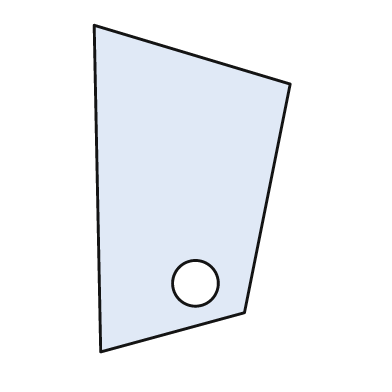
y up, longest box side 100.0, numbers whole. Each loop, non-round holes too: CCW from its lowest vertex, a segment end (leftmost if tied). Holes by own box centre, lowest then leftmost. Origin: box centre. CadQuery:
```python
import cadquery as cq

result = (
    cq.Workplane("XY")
    .moveTo(-28.0, -50.0)
    .lineTo(16.0, -38.0)
    .lineTo(30.0, 32.0)
    .lineTo(-30.0, 50.0)
    .close()
    .moveTo(1.0, -29.0)
    .circle(7.0)
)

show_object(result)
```